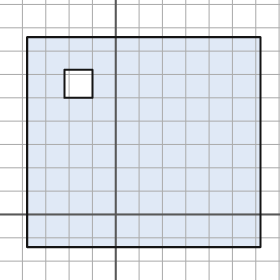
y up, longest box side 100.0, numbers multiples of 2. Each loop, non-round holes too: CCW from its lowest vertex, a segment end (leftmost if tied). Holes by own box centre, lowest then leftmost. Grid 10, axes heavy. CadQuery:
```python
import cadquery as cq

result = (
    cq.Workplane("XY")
    .moveTo(-38.0, -14.0)
    .lineTo(62.0, -14.0)
    .lineTo(62.0, 76.0)
    .lineTo(-38.0, 76.0)
    .close()
    .moveTo(-22.0, 50.0)
    .lineTo(-10.0, 50.0)
    .lineTo(-10.0, 62.0)
    .lineTo(-22.0, 62.0)
    .close()
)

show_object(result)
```